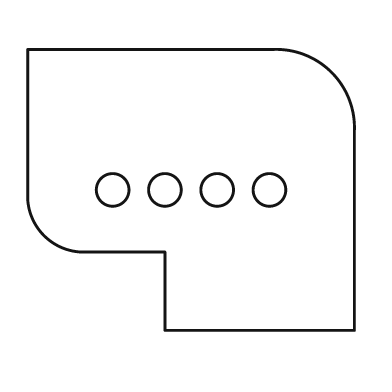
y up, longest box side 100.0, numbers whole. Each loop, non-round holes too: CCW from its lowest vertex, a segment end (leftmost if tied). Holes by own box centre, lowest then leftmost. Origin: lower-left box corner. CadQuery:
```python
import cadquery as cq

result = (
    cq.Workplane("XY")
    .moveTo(42.0, 0.0)
    .lineTo(100.0, 0.0)
    .lineTo(100.0, 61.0)
    .threePointArc((93.0, 79.0), (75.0, 86.0))
    .lineTo(0.0, 86.0)
    .lineTo(0.0, 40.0)
    .threePointArc((5.0, 29.0), (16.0, 24.0))
    .lineTo(42.0, 24.0)
    .close()
    .moveTo(26.0, 43.0)
    .circle(5.0)
    .moveTo(42.0, 43.0)
    .circle(5.0)
    .moveTo(58.0, 43.0)
    .circle(5.0)
    .moveTo(74.0, 43.0)
    .circle(5.0)
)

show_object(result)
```